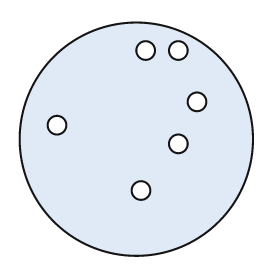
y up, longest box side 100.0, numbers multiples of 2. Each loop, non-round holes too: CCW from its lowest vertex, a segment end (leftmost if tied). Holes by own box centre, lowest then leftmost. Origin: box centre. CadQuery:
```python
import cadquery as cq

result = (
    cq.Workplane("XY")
    .moveTo(0.0, 0.0)
    .circle(50.0)
    .moveTo(2.0, -22.0)
    .circle(4.0)
    .moveTo(18.0, -2.0)
    .circle(4.0)
    .moveTo(-34.0, 6.0)
    .circle(4.0)
    .moveTo(26.0, 16.0)
    .circle(4.0)
    .moveTo(4.0, 38.0)
    .circle(4.0)
    .moveTo(18.0, 38.0)
    .circle(4.0)
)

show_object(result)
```